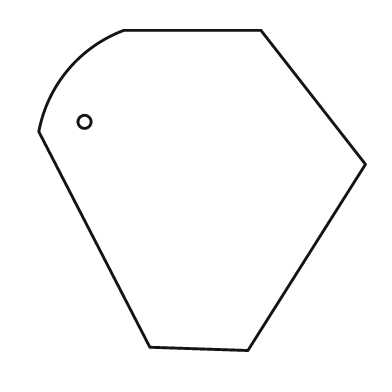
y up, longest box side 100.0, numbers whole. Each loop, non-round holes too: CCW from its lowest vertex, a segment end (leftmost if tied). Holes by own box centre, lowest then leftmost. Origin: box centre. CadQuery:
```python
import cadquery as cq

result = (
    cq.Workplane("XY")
    .moveTo(14.0, -49.0)
    .lineTo(50.0, 8.0)
    .lineTo(18.0, 49.0)
    .lineTo(-24.0, 49.0)
    .threePointArc((-41.0, 37.0), (-50.0, 18.0))
    .lineTo(-16.0, -48.0)
    .close()
    .moveTo(-36.0, 21.0)
    .circle(2.0)
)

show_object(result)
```